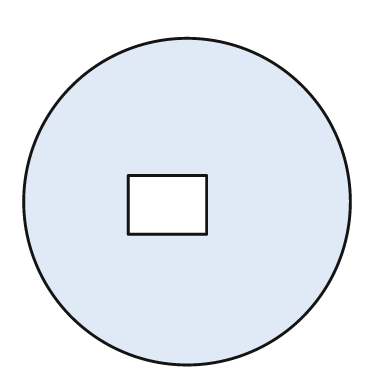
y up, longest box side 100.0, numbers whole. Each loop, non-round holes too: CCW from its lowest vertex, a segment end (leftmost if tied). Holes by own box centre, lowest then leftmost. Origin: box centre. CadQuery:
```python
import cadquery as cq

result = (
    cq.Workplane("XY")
    .moveTo(0.0, 0.0)
    .circle(50.0)
    .moveTo(-18.0, -10.0)
    .lineTo(6.0, -10.0)
    .lineTo(6.0, 8.0)
    .lineTo(-18.0, 8.0)
    .close()
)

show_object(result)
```